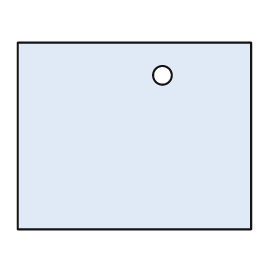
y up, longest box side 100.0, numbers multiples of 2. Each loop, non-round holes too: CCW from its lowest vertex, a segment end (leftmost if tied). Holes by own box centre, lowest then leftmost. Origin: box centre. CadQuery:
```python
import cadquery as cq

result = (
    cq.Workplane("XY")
    .moveTo(-50.0, -40.0)
    .lineTo(50.0, -40.0)
    .lineTo(50.0, 40.0)
    .lineTo(-50.0, 40.0)
    .close()
    .moveTo(12.0, 26.0)
    .circle(4.0)
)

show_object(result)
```